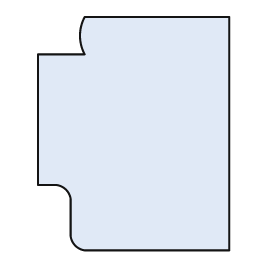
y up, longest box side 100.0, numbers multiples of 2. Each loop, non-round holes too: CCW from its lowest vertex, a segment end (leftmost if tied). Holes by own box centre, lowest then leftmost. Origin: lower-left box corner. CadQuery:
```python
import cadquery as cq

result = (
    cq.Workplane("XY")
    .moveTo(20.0, 0.0)
    .lineTo(82.0, 0.0)
    .lineTo(82.0, 100.0)
    .lineTo(20.0, 100.0)
    .threePointArc((18.0, 92.0), (20.0, 84.0))
    .lineTo(0.0, 84.0)
    .lineTo(0.0, 28.0)
    .lineTo(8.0, 28.0)
    .threePointArc((12.0, 26.0), (14.0, 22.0))
    .lineTo(14.0, 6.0)
    .threePointArc((16.0, 2.0), (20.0, 0.0))
    .close()
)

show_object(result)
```